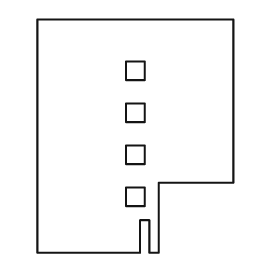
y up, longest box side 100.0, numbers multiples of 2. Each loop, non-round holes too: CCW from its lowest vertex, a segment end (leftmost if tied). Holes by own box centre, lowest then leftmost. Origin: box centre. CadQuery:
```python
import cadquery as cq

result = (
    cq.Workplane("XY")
    .moveTo(-42.0, -50.0)
    .lineTo(2.0, -50.0)
    .lineTo(2.0, -36.0)
    .lineTo(6.0, -36.0)
    .lineTo(6.0, -50.0)
    .lineTo(10.0, -50.0)
    .lineTo(10.0, -20.0)
    .lineTo(42.0, -20.0)
    .lineTo(42.0, 50.0)
    .lineTo(-42.0, 50.0)
    .close()
    .moveTo(-4.0, -30.0)
    .lineTo(4.0, -30.0)
    .lineTo(4.0, -22.0)
    .lineTo(-4.0, -22.0)
    .close()
    .moveTo(-4.0, -12.0)
    .lineTo(4.0, -12.0)
    .lineTo(4.0, -4.0)
    .lineTo(-4.0, -4.0)
    .close()
    .moveTo(-4.0, 6.0)
    .lineTo(4.0, 6.0)
    .lineTo(4.0, 14.0)
    .lineTo(-4.0, 14.0)
    .close()
    .moveTo(-4.0, 24.0)
    .lineTo(4.0, 24.0)
    .lineTo(4.0, 32.0)
    .lineTo(-4.0, 32.0)
    .close()
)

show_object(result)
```